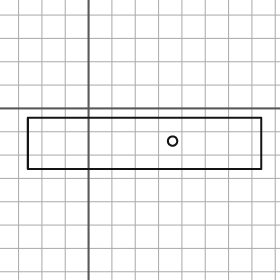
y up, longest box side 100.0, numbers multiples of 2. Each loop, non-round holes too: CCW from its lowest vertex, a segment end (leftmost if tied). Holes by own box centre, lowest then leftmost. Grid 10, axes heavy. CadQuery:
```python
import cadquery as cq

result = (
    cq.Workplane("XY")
    .moveTo(-26.0, -26.0)
    .lineTo(74.0, -26.0)
    .lineTo(74.0, -4.0)
    .lineTo(-26.0, -4.0)
    .close()
    .moveTo(36.0, -14.0)
    .circle(2.0)
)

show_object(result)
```